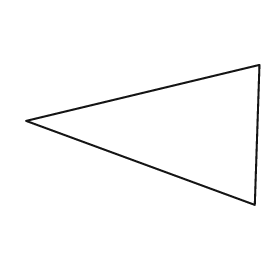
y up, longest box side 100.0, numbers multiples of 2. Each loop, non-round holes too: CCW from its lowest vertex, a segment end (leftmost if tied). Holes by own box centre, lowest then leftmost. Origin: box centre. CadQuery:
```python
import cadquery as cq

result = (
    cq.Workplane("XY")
    .moveTo(48.0, -30.0)
    .lineTo(50.0, 30.0)
    .lineTo(-50.0, 6.0)
    .close()
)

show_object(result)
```